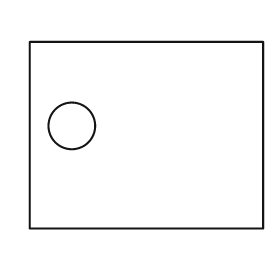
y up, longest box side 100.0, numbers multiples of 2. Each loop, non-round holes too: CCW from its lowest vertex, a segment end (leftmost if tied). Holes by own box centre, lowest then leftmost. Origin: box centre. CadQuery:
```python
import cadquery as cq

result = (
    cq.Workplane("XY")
    .moveTo(-50.0, -40.0)
    .lineTo(50.0, -40.0)
    .lineTo(50.0, 40.0)
    .lineTo(-50.0, 40.0)
    .close()
    .moveTo(-32.0, 4.0)
    .circle(10.0)
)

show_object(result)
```